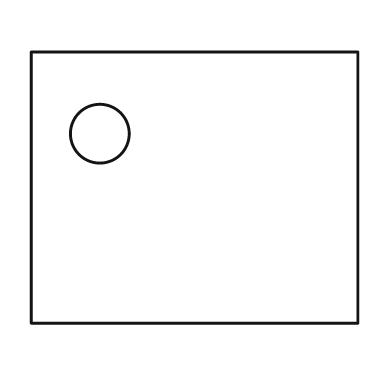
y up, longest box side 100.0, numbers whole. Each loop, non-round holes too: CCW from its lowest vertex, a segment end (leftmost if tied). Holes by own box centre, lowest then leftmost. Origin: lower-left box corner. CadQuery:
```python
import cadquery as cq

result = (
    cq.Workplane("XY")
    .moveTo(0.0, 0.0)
    .lineTo(100.0, 0.0)
    .lineTo(100.0, 83.0)
    .lineTo(0.0, 83.0)
    .close()
    .moveTo(21.0, 58.0)
    .circle(9.0)
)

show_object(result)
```